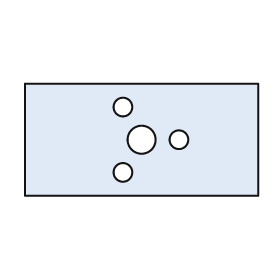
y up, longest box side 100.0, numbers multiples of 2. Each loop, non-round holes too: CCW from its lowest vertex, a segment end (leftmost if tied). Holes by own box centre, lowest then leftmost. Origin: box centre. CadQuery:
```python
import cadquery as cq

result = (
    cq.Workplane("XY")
    .moveTo(-50.0, -24.0)
    .lineTo(50.0, -24.0)
    .lineTo(50.0, 24.0)
    .lineTo(-50.0, 24.0)
    .close()
    .moveTo(-8.0, -14.0)
    .circle(4.0)
    .moveTo(0.0, 0.0)
    .circle(6.0)
    .moveTo(16.0, 0.0)
    .circle(4.0)
    .moveTo(-8.0, 14.0)
    .circle(4.0)
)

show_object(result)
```